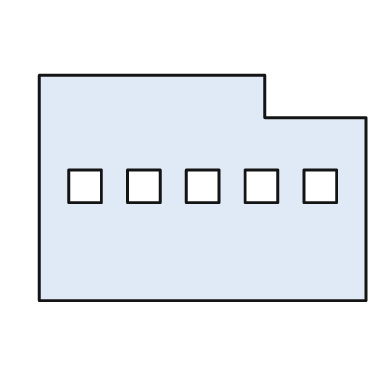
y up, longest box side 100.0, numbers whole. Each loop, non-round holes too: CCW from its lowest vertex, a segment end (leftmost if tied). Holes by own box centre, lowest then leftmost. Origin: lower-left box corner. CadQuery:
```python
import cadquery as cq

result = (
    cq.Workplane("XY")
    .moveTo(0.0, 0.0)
    .lineTo(100.0, 0.0)
    .lineTo(100.0, 56.0)
    .lineTo(69.0, 56.0)
    .lineTo(69.0, 69.0)
    .lineTo(0.0, 69.0)
    .close()
    .moveTo(9.0, 30.0)
    .lineTo(19.0, 30.0)
    .lineTo(19.0, 40.0)
    .lineTo(9.0, 40.0)
    .close()
    .moveTo(27.0, 30.0)
    .lineTo(37.0, 30.0)
    .lineTo(37.0, 40.0)
    .lineTo(27.0, 40.0)
    .close()
    .moveTo(45.0, 30.0)
    .lineTo(55.0, 30.0)
    .lineTo(55.0, 40.0)
    .lineTo(45.0, 40.0)
    .close()
    .moveTo(63.0, 30.0)
    .lineTo(73.0, 30.0)
    .lineTo(73.0, 40.0)
    .lineTo(63.0, 40.0)
    .close()
    .moveTo(81.0, 30.0)
    .lineTo(91.0, 30.0)
    .lineTo(91.0, 40.0)
    .lineTo(81.0, 40.0)
    .close()
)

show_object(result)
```